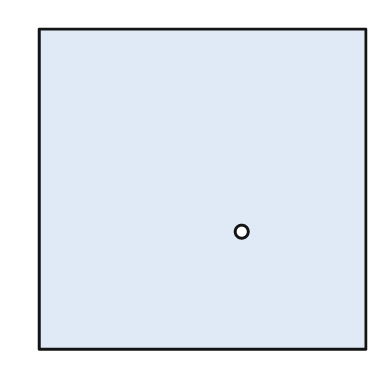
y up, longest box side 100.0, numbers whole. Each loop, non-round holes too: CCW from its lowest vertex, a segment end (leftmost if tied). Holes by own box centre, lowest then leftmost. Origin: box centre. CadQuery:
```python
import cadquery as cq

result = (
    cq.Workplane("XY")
    .moveTo(-50.0, -49.0)
    .lineTo(50.0, -49.0)
    .lineTo(50.0, 49.0)
    .lineTo(-50.0, 49.0)
    .close()
    .moveTo(12.0, -13.0)
    .circle(2.0)
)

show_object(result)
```